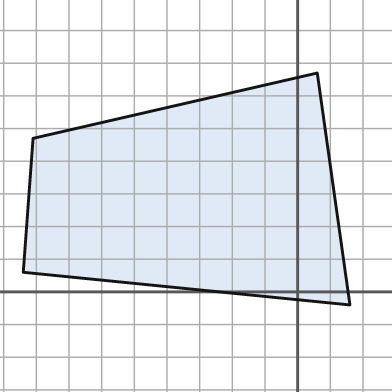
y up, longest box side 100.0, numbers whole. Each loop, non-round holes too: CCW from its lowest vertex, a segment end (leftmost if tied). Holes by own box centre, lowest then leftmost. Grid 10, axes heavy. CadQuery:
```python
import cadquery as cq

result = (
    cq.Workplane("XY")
    .moveTo(16.0, -4.0)
    .lineTo(6.0, 67.0)
    .lineTo(-81.0, 47.0)
    .lineTo(-84.0, 6.0)
    .close()
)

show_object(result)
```